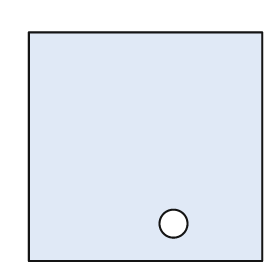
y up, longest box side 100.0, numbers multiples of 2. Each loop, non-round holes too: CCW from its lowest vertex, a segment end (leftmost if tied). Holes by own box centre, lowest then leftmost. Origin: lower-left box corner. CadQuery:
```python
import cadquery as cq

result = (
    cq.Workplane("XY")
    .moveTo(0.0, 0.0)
    .lineTo(100.0, 0.0)
    .lineTo(100.0, 98.0)
    .lineTo(0.0, 98.0)
    .close()
    .moveTo(62.0, 16.0)
    .circle(6.0)
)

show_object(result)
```